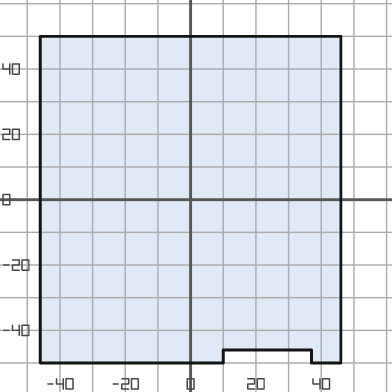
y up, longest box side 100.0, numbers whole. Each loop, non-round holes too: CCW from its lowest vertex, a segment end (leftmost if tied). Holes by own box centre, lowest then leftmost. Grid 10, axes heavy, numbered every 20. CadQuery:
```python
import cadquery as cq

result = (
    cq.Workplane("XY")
    .moveTo(-46.0, -50.0)
    .lineTo(10.0, -50.0)
    .lineTo(10.0, -46.0)
    .lineTo(37.0, -46.0)
    .lineTo(37.0, -50.0)
    .lineTo(46.0, -50.0)
    .lineTo(46.0, 50.0)
    .lineTo(-46.0, 50.0)
    .close()
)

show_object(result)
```